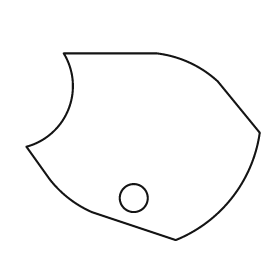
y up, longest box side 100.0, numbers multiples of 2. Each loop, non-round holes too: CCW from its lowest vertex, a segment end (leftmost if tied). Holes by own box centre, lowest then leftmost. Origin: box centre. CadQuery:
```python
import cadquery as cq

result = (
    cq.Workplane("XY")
    .moveTo(14.0, -40.0)
    .threePointArc((38.0, -22.0), (50.0, 6.0))
    .lineTo(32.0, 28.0)
    .threePointArc((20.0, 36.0), (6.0, 40.0))
    .lineTo(-34.0, 40.0)
    .threePointArc((-32.0, 16.0), (-50.0, 0.0))
    .lineTo(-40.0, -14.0)
    .threePointArc((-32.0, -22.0), (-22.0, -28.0))
    .close()
    .moveTo(-4.0, -22.0)
    .circle(6.0)
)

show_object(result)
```